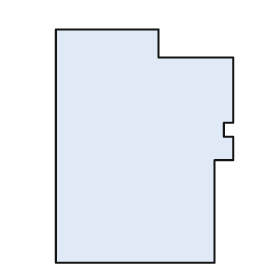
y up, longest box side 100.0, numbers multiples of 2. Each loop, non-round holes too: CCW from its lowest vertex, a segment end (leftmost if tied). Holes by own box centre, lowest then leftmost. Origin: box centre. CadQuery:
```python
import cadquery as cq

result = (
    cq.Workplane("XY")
    .moveTo(-38.0, -50.0)
    .lineTo(30.0, -50.0)
    .lineTo(30.0, -6.0)
    .lineTo(38.0, -6.0)
    .lineTo(38.0, 4.0)
    .lineTo(34.0, 4.0)
    .lineTo(34.0, 10.0)
    .lineTo(38.0, 10.0)
    .lineTo(38.0, 38.0)
    .lineTo(6.0, 38.0)
    .lineTo(6.0, 50.0)
    .lineTo(-38.0, 50.0)
    .close()
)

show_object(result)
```